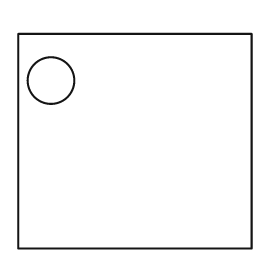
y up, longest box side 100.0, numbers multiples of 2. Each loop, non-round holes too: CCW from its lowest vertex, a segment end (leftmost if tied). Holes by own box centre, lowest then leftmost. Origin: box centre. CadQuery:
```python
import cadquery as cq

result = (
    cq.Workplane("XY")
    .moveTo(-50.0, -46.0)
    .lineTo(50.0, -46.0)
    .lineTo(50.0, 46.0)
    .lineTo(-50.0, 46.0)
    .close()
    .moveTo(-36.0, 26.0)
    .circle(10.0)
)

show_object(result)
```